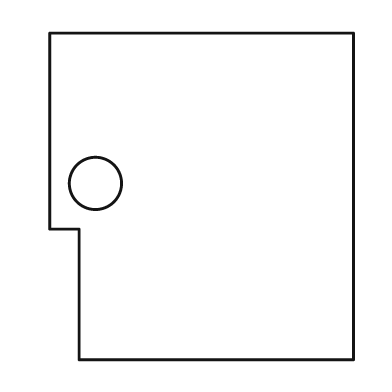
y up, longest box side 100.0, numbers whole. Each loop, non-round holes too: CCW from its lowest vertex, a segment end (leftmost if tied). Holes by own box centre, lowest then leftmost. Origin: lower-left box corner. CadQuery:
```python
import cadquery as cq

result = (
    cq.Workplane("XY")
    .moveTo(9.0, 0.0)
    .lineTo(93.0, 0.0)
    .lineTo(93.0, 100.0)
    .lineTo(0.0, 100.0)
    .lineTo(0.0, 40.0)
    .lineTo(9.0, 40.0)
    .close()
    .moveTo(14.0, 54.0)
    .circle(8.0)
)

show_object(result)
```